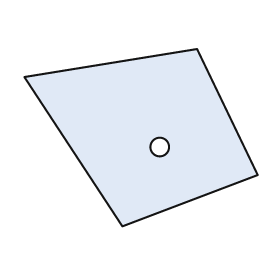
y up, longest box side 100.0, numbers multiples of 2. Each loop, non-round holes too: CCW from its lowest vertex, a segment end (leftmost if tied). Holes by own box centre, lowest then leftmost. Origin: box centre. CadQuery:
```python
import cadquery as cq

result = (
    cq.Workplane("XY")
    .moveTo(-8.0, -38.0)
    .lineTo(50.0, -16.0)
    .lineTo(24.0, 38.0)
    .lineTo(-50.0, 26.0)
    .close()
    .moveTo(8.0, -4.0)
    .circle(4.0)
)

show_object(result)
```